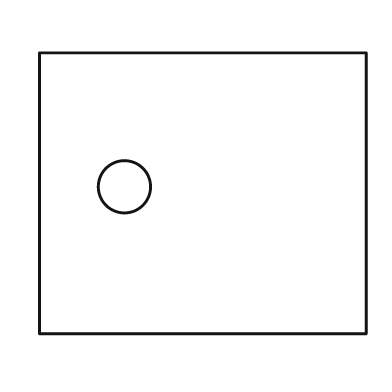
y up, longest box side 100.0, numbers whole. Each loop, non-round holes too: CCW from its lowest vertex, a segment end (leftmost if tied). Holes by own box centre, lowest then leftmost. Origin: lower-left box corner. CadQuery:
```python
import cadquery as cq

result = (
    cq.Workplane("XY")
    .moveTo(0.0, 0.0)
    .lineTo(100.0, 0.0)
    .lineTo(100.0, 86.0)
    .lineTo(0.0, 86.0)
    .close()
    .moveTo(26.0, 45.0)
    .circle(8.0)
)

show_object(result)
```